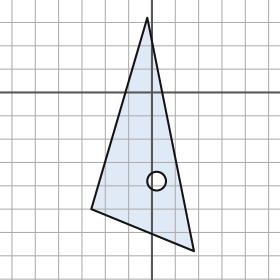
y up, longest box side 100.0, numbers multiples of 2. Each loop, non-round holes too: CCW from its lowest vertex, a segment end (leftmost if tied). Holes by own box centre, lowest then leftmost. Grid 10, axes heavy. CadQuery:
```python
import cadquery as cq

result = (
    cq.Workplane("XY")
    .moveTo(18.0, -68.0)
    .lineTo(-2.0, 32.0)
    .lineTo(-26.0, -50.0)
    .close()
    .moveTo(2.0, -38.0)
    .circle(4.0)
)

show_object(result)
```